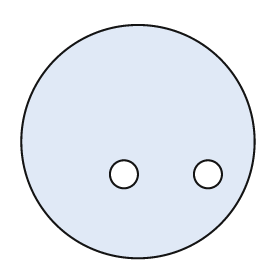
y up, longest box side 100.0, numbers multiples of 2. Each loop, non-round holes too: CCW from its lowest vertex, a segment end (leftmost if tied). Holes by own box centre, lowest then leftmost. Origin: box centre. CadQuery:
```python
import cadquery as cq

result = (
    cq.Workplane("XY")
    .moveTo(0.0, 0.0)
    .circle(50.0)
    .moveTo(-6.0, -14.0)
    .circle(6.0)
    .moveTo(30.0, -14.0)
    .circle(6.0)
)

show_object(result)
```